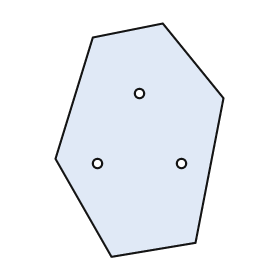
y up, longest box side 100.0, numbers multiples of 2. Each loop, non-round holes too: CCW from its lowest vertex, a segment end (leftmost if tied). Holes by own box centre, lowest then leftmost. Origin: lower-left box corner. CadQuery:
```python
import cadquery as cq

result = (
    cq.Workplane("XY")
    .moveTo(24.0, 0.0)
    .lineTo(60.0, 6.0)
    .lineTo(72.0, 68.0)
    .lineTo(46.0, 100.0)
    .lineTo(16.0, 94.0)
    .lineTo(0.0, 42.0)
    .close()
    .moveTo(18.0, 40.0)
    .circle(2.0)
    .moveTo(54.0, 40.0)
    .circle(2.0)
    .moveTo(36.0, 70.0)
    .circle(2.0)
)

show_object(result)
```